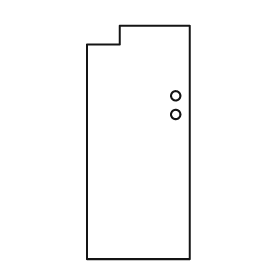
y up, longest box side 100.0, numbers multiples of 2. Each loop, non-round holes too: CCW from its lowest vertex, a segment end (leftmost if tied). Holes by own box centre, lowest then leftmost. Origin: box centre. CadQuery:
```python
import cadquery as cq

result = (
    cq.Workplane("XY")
    .moveTo(-22.0, -50.0)
    .lineTo(22.0, -50.0)
    .lineTo(22.0, 50.0)
    .lineTo(-8.0, 50.0)
    .lineTo(-8.0, 42.0)
    .lineTo(-22.0, 42.0)
    .close()
    .moveTo(16.0, 12.0)
    .circle(2.0)
    .moveTo(16.0, 20.0)
    .circle(2.0)
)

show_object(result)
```